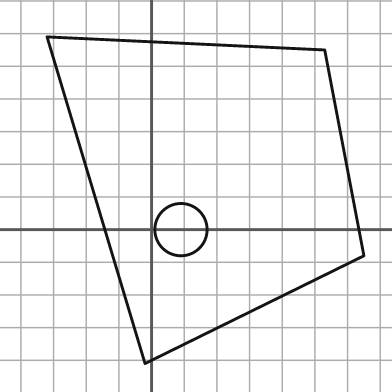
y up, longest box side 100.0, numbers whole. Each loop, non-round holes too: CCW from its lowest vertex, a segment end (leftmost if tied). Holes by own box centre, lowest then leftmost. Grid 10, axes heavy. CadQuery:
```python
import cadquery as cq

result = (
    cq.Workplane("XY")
    .moveTo(-2.0, -41.0)
    .lineTo(65.0, -8.0)
    .lineTo(53.0, 55.0)
    .lineTo(-32.0, 59.0)
    .close()
    .moveTo(9.0, 0.0)
    .circle(8.0)
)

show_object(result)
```